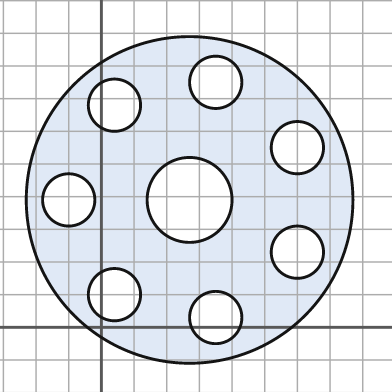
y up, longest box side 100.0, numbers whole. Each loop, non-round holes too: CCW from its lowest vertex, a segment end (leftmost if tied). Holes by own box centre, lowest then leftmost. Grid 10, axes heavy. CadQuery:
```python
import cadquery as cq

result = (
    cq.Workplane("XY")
    .moveTo(27.0, 39.0)
    .circle(50.0)
    .moveTo(35.0, 3.0)
    .circle(8.0)
    .moveTo(4.0, 10.0)
    .circle(8.0)
    .moveTo(60.0, 23.0)
    .circle(8.0)
    .moveTo(-10.0, 39.0)
    .circle(8.0)
    .moveTo(27.0, 39.0)
    .circle(13.0)
    .moveTo(60.0, 55.0)
    .circle(8.0)
    .moveTo(4.0, 68.0)
    .circle(8.0)
    .moveTo(35.0, 75.0)
    .circle(8.0)
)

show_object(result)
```